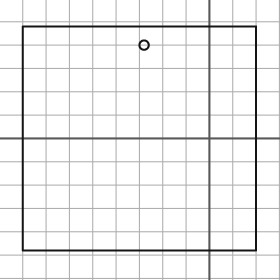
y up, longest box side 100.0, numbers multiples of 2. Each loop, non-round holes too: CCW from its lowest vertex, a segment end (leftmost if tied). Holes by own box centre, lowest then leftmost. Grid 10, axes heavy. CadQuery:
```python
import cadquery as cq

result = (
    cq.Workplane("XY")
    .moveTo(-80.0, -48.0)
    .lineTo(20.0, -48.0)
    .lineTo(20.0, 48.0)
    .lineTo(-80.0, 48.0)
    .close()
    .moveTo(-28.0, 40.0)
    .circle(2.0)
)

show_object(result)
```